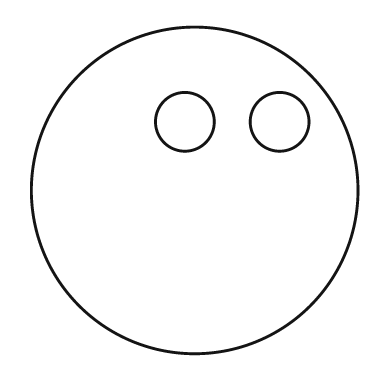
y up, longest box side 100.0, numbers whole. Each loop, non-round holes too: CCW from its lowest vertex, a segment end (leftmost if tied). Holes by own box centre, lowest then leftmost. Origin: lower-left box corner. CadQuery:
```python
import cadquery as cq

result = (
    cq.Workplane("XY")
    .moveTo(50.0, 50.0)
    .circle(50.0)
    .moveTo(47.0, 71.0)
    .circle(9.0)
    .moveTo(76.0, 71.0)
    .circle(9.0)
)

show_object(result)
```